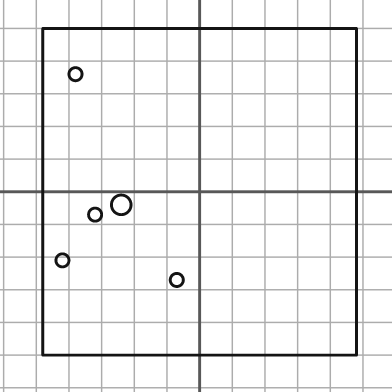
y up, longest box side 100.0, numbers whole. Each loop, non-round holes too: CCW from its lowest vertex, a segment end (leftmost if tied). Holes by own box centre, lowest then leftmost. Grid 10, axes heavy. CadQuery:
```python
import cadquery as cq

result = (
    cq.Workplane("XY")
    .moveTo(-48.0, -50.0)
    .lineTo(48.0, -50.0)
    .lineTo(48.0, 50.0)
    .lineTo(-48.0, 50.0)
    .close()
    .moveTo(-7.0, -27.0)
    .circle(2.0)
    .moveTo(-42.0, -21.0)
    .circle(2.0)
    .moveTo(-32.0, -7.0)
    .circle(2.0)
    .moveTo(-24.0, -4.0)
    .circle(3.0)
    .moveTo(-38.0, 36.0)
    .circle(2.0)
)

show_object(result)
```